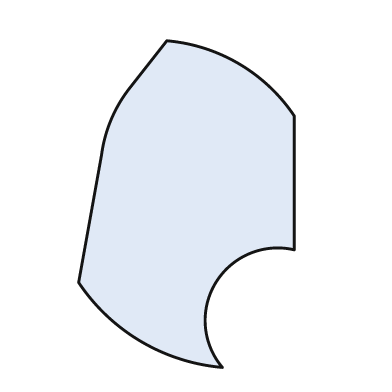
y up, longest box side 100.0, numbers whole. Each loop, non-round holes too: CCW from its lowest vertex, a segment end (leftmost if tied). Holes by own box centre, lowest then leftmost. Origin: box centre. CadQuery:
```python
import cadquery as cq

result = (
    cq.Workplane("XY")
    .moveTo(11.0, -50.0)
    .threePointArc((9.0, -24.0), (33.0, -14.0))
    .lineTo(33.0, 27.0)
    .threePointArc((16.0, 43.0), (-6.0, 50.0))
    .lineTo(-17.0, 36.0)
    .threePointArc((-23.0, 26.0), (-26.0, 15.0))
    .lineTo(-33.0, -24.0)
    .threePointArc((-14.0, -42.0), (11.0, -50.0))
    .close()
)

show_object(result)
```